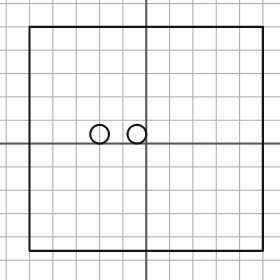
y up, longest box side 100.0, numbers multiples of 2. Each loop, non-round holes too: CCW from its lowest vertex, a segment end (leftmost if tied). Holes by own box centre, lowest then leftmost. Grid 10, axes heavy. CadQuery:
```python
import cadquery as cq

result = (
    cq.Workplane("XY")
    .moveTo(-50.0, -46.0)
    .lineTo(50.0, -46.0)
    .lineTo(50.0, 50.0)
    .lineTo(-50.0, 50.0)
    .close()
    .moveTo(-20.0, 4.0)
    .circle(4.0)
    .moveTo(-4.0, 4.0)
    .circle(4.0)
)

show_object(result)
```